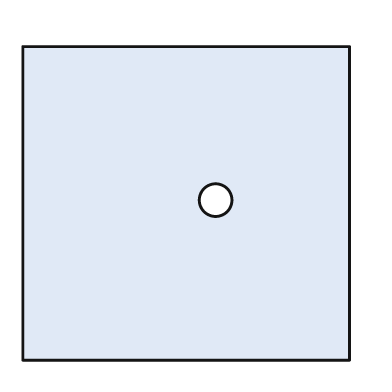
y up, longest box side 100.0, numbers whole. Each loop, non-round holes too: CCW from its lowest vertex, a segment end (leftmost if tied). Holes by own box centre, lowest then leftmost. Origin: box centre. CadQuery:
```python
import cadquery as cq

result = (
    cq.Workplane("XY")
    .moveTo(-50.0, -48.0)
    .lineTo(50.0, -48.0)
    .lineTo(50.0, 48.0)
    .lineTo(-50.0, 48.0)
    .close()
    .moveTo(9.0, 1.0)
    .circle(5.0)
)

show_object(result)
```